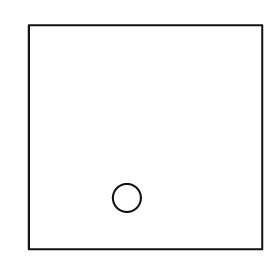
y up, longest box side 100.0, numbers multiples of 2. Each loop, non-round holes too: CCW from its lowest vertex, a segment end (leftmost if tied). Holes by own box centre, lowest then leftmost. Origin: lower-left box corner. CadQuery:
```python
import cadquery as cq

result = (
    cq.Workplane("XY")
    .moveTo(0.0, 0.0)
    .lineTo(100.0, 0.0)
    .lineTo(100.0, 96.0)
    .lineTo(0.0, 96.0)
    .close()
    .moveTo(42.0, 22.0)
    .circle(6.0)
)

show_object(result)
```